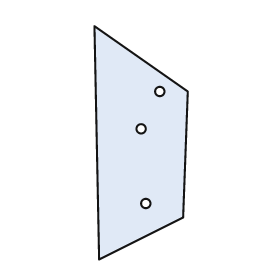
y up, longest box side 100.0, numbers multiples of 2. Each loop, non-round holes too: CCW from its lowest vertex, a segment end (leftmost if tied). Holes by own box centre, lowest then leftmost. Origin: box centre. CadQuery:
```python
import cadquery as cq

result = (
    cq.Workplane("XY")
    .moveTo(-18.0, -50.0)
    .lineTo(18.0, -32.0)
    .lineTo(20.0, 22.0)
    .lineTo(-20.0, 50.0)
    .close()
    .moveTo(2.0, -26.0)
    .circle(2.0)
    .moveTo(0.0, 6.0)
    .circle(2.0)
    .moveTo(8.0, 22.0)
    .circle(2.0)
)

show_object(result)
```